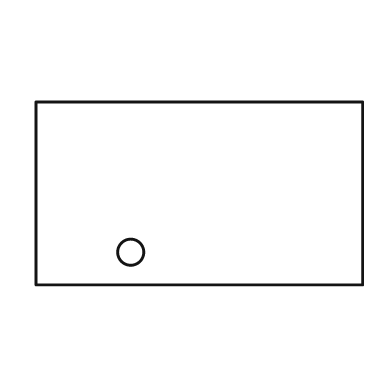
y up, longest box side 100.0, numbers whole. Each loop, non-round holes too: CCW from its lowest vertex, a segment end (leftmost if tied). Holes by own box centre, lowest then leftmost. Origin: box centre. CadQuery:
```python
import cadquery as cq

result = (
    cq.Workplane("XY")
    .moveTo(-50.0, -28.0)
    .lineTo(50.0, -28.0)
    .lineTo(50.0, 28.0)
    .lineTo(-50.0, 28.0)
    .close()
    .moveTo(-21.0, -18.0)
    .circle(4.0)
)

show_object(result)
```